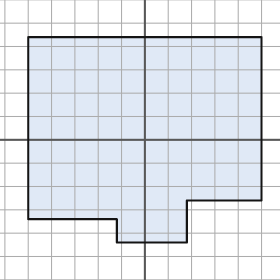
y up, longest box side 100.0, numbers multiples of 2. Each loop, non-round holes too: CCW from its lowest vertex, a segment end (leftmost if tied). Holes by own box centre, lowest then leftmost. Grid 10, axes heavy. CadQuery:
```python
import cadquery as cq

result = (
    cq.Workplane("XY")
    .moveTo(-12.0, -44.0)
    .lineTo(18.0, -44.0)
    .lineTo(18.0, -26.0)
    .lineTo(50.0, -26.0)
    .lineTo(50.0, 44.0)
    .lineTo(-50.0, 44.0)
    .lineTo(-50.0, -34.0)
    .lineTo(-12.0, -34.0)
    .close()
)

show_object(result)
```